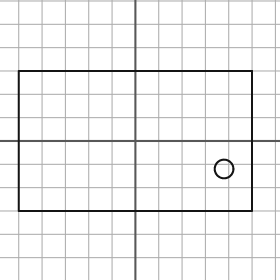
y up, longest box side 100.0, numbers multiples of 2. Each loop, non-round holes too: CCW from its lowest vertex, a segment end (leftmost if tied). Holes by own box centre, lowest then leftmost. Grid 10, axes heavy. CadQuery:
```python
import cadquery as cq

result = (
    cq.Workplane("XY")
    .moveTo(-50.0, -30.0)
    .lineTo(50.0, -30.0)
    .lineTo(50.0, 30.0)
    .lineTo(-50.0, 30.0)
    .close()
    .moveTo(38.0, -12.0)
    .circle(4.0)
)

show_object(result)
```